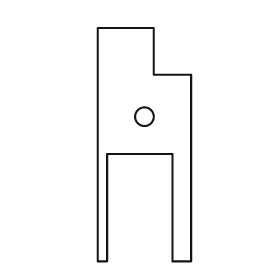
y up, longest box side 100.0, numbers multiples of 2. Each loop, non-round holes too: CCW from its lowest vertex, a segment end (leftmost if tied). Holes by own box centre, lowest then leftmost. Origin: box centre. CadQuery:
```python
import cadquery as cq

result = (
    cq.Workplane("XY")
    .moveTo(-20.0, -50.0)
    .lineTo(-16.0, -50.0)
    .lineTo(-16.0, -4.0)
    .lineTo(12.0, -4.0)
    .lineTo(12.0, -50.0)
    .lineTo(20.0, -50.0)
    .lineTo(20.0, 30.0)
    .lineTo(4.0, 30.0)
    .lineTo(4.0, 50.0)
    .lineTo(-20.0, 50.0)
    .close()
    .moveTo(0.0, 12.0)
    .circle(4.0)
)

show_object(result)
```